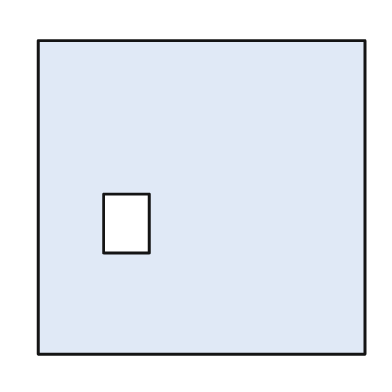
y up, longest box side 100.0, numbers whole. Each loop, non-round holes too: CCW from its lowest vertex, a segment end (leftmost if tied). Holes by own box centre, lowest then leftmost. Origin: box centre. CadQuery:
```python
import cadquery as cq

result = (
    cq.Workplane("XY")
    .moveTo(-50.0, -48.0)
    .lineTo(50.0, -48.0)
    .lineTo(50.0, 48.0)
    .lineTo(-50.0, 48.0)
    .close()
    .moveTo(-30.0, -17.0)
    .lineTo(-16.0, -17.0)
    .lineTo(-16.0, 1.0)
    .lineTo(-30.0, 1.0)
    .close()
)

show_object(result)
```